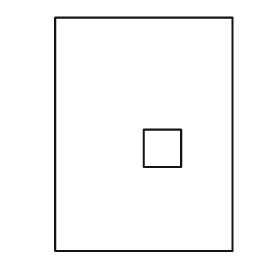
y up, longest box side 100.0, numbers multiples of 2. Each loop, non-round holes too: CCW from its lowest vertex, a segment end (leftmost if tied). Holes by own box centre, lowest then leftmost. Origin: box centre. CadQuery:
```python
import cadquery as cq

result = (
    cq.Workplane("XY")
    .moveTo(-38.0, -50.0)
    .lineTo(38.0, -50.0)
    .lineTo(38.0, 50.0)
    .lineTo(-38.0, 50.0)
    .close()
    .moveTo(0.0, -14.0)
    .lineTo(16.0, -14.0)
    .lineTo(16.0, 2.0)
    .lineTo(0.0, 2.0)
    .close()
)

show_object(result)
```